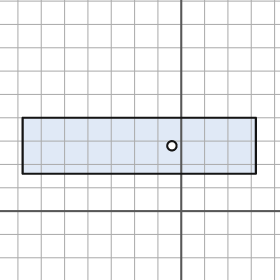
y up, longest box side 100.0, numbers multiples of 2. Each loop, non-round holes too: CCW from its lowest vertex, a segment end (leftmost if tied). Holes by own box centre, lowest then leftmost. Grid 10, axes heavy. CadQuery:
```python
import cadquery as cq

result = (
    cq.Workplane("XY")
    .moveTo(-68.0, 16.0)
    .lineTo(32.0, 16.0)
    .lineTo(32.0, 40.0)
    .lineTo(-68.0, 40.0)
    .close()
    .moveTo(-4.0, 28.0)
    .circle(2.0)
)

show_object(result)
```